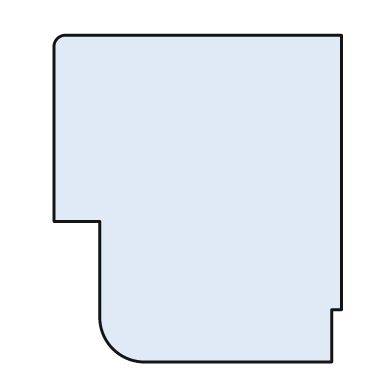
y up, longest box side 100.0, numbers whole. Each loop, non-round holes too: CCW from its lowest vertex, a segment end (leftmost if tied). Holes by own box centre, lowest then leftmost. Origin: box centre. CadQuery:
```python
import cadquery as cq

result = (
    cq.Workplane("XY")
    .moveTo(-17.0, -50.0)
    .lineTo(41.0, -50.0)
    .lineTo(41.0, -34.0)
    .lineTo(44.0, -34.0)
    .lineTo(44.0, 50.0)
    .lineTo(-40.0, 50.0)
    .threePointArc((-43.0, 49.0), (-44.0, 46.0))
    .lineTo(-44.0, -7.0)
    .lineTo(-30.0, -7.0)
    .lineTo(-30.0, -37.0)
    .threePointArc((-26.0, -46.0), (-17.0, -50.0))
    .close()
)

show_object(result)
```